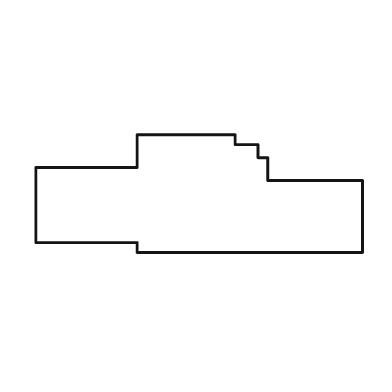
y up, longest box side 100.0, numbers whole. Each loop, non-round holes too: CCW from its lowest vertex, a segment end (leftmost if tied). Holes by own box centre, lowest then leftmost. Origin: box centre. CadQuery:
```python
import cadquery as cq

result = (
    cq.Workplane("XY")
    .moveTo(-19.0, -18.0)
    .lineTo(50.0, -18.0)
    .lineTo(50.0, 4.0)
    .lineTo(21.0, 4.0)
    .lineTo(21.0, 11.0)
    .lineTo(18.0, 11.0)
    .lineTo(18.0, 15.0)
    .lineTo(11.0, 15.0)
    .lineTo(11.0, 18.0)
    .lineTo(-19.0, 18.0)
    .lineTo(-19.0, 8.0)
    .lineTo(-50.0, 8.0)
    .lineTo(-50.0, -15.0)
    .lineTo(-19.0, -15.0)
    .close()
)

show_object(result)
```